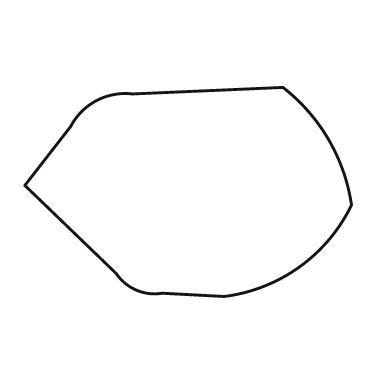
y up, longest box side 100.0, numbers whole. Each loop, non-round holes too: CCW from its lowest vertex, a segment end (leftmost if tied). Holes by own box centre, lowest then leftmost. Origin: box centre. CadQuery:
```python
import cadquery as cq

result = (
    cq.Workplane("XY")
    .moveTo(11.0, -32.0)
    .threePointArc((34.0, -23.0), (50.0, -4.0))
    .threePointArc((43.0, 16.0), (29.0, 32.0))
    .lineTo(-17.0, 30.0)
    .threePointArc((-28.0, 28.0), (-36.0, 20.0))
    .lineTo(-50.0, 2.0)
    .lineTo(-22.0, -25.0)
    .threePointArc((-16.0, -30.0), (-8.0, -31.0))
    .close()
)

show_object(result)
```